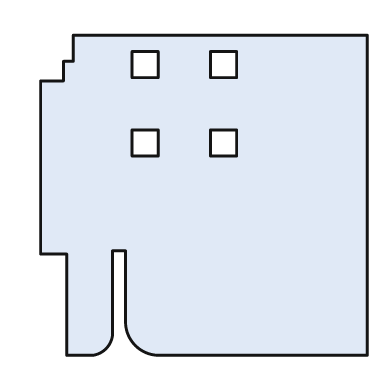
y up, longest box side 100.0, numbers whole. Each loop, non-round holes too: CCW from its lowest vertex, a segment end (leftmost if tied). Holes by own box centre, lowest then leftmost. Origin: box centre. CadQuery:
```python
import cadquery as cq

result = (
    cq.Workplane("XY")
    .moveTo(-42.0, -49.0)
    .lineTo(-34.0, -49.0)
    .threePointArc((-30.0, -47.0), (-28.0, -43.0))
    .lineTo(-28.0, -17.0)
    .lineTo(-24.0, -17.0)
    .lineTo(-24.0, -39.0)
    .threePointArc((-21.0, -46.0), (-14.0, -49.0))
    .lineTo(50.0, -49.0)
    .lineTo(50.0, 49.0)
    .lineTo(-40.0, 49.0)
    .lineTo(-40.0, 41.0)
    .lineTo(-43.0, 41.0)
    .lineTo(-43.0, 35.0)
    .lineTo(-50.0, 35.0)
    .lineTo(-50.0, -18.0)
    .lineTo(-42.0, -18.0)
    .close()
    .moveTo(-22.0, 12.0)
    .lineTo(-14.0, 12.0)
    .lineTo(-14.0, 20.0)
    .lineTo(-22.0, 20.0)
    .close()
    .moveTo(2.0, 12.0)
    .lineTo(10.0, 12.0)
    .lineTo(10.0, 20.0)
    .lineTo(2.0, 20.0)
    .close()
    .moveTo(-22.0, 36.0)
    .lineTo(-14.0, 36.0)
    .lineTo(-14.0, 44.0)
    .lineTo(-22.0, 44.0)
    .close()
    .moveTo(2.0, 36.0)
    .lineTo(10.0, 36.0)
    .lineTo(10.0, 44.0)
    .lineTo(2.0, 44.0)
    .close()
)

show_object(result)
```